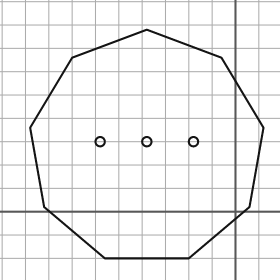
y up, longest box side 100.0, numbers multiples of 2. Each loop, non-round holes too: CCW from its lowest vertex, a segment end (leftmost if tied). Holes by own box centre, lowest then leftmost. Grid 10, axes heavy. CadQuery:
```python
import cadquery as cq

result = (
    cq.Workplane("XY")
    .moveTo(-56.0, -20.0)
    .lineTo(-20.0, -20.0)
    .lineTo(6.0, 2.0)
    .lineTo(12.0, 36.0)
    .lineTo(-6.0, 66.0)
    .lineTo(-38.0, 78.0)
    .lineTo(-70.0, 66.0)
    .lineTo(-88.0, 36.0)
    .lineTo(-82.0, 2.0)
    .close()
    .moveTo(-58.0, 30.0)
    .circle(2.0)
    .moveTo(-38.0, 30.0)
    .circle(2.0)
    .moveTo(-18.0, 30.0)
    .circle(2.0)
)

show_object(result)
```